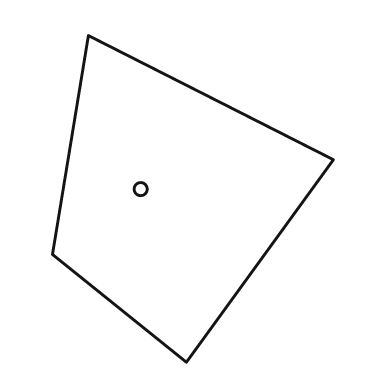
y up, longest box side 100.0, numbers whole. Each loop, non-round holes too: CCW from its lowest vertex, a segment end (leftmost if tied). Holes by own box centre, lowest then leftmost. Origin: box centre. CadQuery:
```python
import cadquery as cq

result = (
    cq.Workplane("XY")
    .moveTo(-2.0, -50.0)
    .lineTo(43.0, 12.0)
    .lineTo(-32.0, 50.0)
    .lineTo(-43.0, -17.0)
    .close()
    .moveTo(-16.0, 3.0)
    .circle(2.0)
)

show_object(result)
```